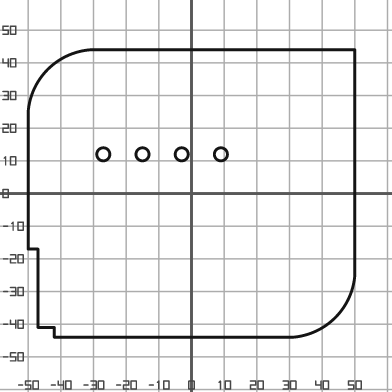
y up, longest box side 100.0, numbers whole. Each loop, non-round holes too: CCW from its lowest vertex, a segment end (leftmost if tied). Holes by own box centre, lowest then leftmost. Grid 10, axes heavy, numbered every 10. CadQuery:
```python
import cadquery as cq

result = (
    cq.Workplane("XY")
    .moveTo(-42.0, -44.0)
    .lineTo(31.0, -44.0)
    .threePointArc((44.0, -38.0), (50.0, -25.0))
    .lineTo(50.0, 44.0)
    .lineTo(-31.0, 44.0)
    .threePointArc((-44.0, 38.0), (-50.0, 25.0))
    .lineTo(-50.0, -17.0)
    .lineTo(-47.0, -17.0)
    .lineTo(-47.0, -41.0)
    .lineTo(-42.0, -41.0)
    .close()
    .moveTo(-27.0, 12.0)
    .circle(2.0)
    .moveTo(-15.0, 12.0)
    .circle(2.0)
    .moveTo(-3.0, 12.0)
    .circle(2.0)
    .moveTo(9.0, 12.0)
    .circle(2.0)
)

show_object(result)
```